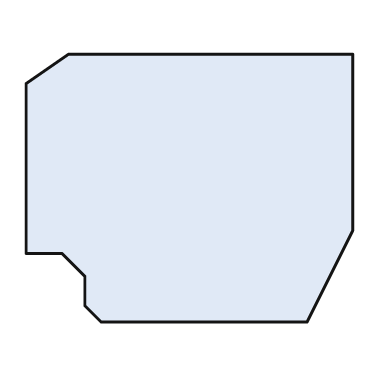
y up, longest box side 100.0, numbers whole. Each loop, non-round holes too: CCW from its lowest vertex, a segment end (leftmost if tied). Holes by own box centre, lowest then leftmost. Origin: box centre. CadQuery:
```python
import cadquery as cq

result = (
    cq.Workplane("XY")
    .moveTo(-27.0, -41.0)
    .lineTo(36.0, -41.0)
    .lineTo(50.0, -13.0)
    .lineTo(50.0, 41.0)
    .lineTo(-37.0, 41.0)
    .lineTo(-50.0, 32.0)
    .lineTo(-50.0, -20.0)
    .lineTo(-39.0, -20.0)
    .lineTo(-32.0, -27.0)
    .lineTo(-32.0, -36.0)
    .close()
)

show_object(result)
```